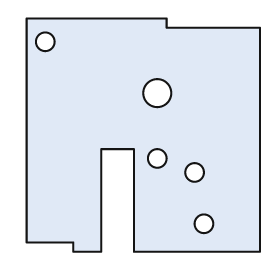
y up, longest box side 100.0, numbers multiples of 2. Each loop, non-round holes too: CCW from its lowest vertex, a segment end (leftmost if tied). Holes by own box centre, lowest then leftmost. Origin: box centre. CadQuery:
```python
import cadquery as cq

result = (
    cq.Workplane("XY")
    .moveTo(-30.0, -50.0)
    .lineTo(-18.0, -50.0)
    .lineTo(-18.0, -6.0)
    .lineTo(-4.0, -6.0)
    .lineTo(-4.0, -50.0)
    .lineTo(50.0, -50.0)
    .lineTo(50.0, 46.0)
    .lineTo(10.0, 46.0)
    .lineTo(10.0, 50.0)
    .lineTo(-50.0, 50.0)
    .lineTo(-50.0, -46.0)
    .lineTo(-30.0, -46.0)
    .close()
    .moveTo(26.0, -38.0)
    .circle(4.0)
    .moveTo(22.0, -16.0)
    .circle(4.0)
    .moveTo(6.0, -10.0)
    .circle(4.0)
    .moveTo(6.0, 18.0)
    .circle(6.0)
    .moveTo(-42.0, 40.0)
    .circle(4.0)
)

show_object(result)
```